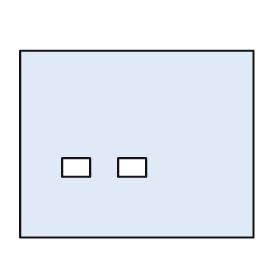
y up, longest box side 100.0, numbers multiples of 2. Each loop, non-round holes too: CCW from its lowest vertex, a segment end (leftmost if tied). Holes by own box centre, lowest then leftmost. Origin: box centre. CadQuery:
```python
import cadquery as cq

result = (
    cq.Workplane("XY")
    .moveTo(-50.0, -40.0)
    .lineTo(50.0, -40.0)
    .lineTo(50.0, 40.0)
    .lineTo(-50.0, 40.0)
    .close()
    .moveTo(-32.0, -14.0)
    .lineTo(-20.0, -14.0)
    .lineTo(-20.0, -6.0)
    .lineTo(-32.0, -6.0)
    .close()
    .moveTo(-8.0, -14.0)
    .lineTo(4.0, -14.0)
    .lineTo(4.0, -6.0)
    .lineTo(-8.0, -6.0)
    .close()
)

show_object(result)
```